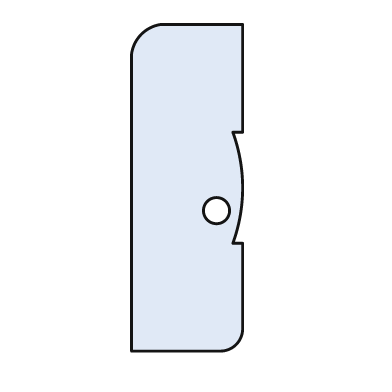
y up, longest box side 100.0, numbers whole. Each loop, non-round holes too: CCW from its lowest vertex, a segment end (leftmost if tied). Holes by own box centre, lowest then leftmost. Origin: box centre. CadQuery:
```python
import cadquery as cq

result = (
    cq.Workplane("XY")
    .moveTo(-17.0, -50.0)
    .lineTo(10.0, -50.0)
    .threePointArc((15.0, -48.0), (17.0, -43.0))
    .lineTo(17.0, -17.0)
    .lineTo(14.0, -17.0)
    .threePointArc((17.0, 0.0), (14.0, 17.0))
    .lineTo(17.0, 17.0)
    .lineTo(17.0, 50.0)
    .lineTo(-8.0, 50.0)
    .threePointArc((-14.0, 47.0), (-17.0, 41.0))
    .close()
    .moveTo(9.0, -7.0)
    .circle(4.0)
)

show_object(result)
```